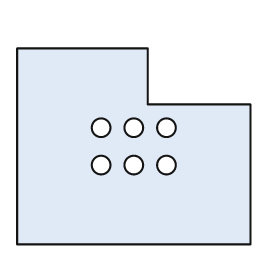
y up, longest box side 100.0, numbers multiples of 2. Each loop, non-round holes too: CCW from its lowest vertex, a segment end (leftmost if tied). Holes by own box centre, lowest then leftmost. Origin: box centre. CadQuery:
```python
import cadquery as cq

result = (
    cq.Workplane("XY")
    .moveTo(-50.0, -42.0)
    .lineTo(50.0, -42.0)
    .lineTo(50.0, 18.0)
    .lineTo(6.0, 18.0)
    .lineTo(6.0, 42.0)
    .lineTo(-50.0, 42.0)
    .close()
    .moveTo(-14.0, -8.0)
    .circle(4.0)
    .moveTo(0.0, -8.0)
    .circle(4.0)
    .moveTo(14.0, -8.0)
    .circle(4.0)
    .moveTo(-14.0, 8.0)
    .circle(4.0)
    .moveTo(0.0, 8.0)
    .circle(4.0)
    .moveTo(14.0, 8.0)
    .circle(4.0)
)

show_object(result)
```